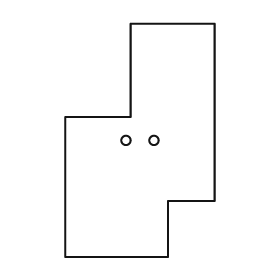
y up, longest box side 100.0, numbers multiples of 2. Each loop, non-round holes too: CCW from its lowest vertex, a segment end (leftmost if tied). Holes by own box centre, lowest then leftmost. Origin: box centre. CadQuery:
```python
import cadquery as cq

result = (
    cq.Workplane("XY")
    .moveTo(-32.0, -50.0)
    .lineTo(12.0, -50.0)
    .lineTo(12.0, -26.0)
    .lineTo(32.0, -26.0)
    .lineTo(32.0, 50.0)
    .lineTo(-4.0, 50.0)
    .lineTo(-4.0, 10.0)
    .lineTo(-32.0, 10.0)
    .close()
    .moveTo(-6.0, 0.0)
    .circle(2.0)
    .moveTo(6.0, 0.0)
    .circle(2.0)
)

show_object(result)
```